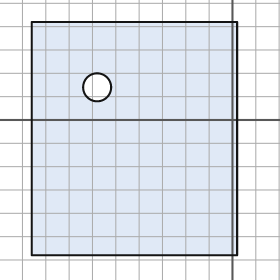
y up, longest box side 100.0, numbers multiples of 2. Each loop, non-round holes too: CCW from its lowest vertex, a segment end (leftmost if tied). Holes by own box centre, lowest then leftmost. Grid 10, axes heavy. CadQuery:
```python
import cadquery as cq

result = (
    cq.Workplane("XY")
    .moveTo(-86.0, -58.0)
    .lineTo(2.0, -58.0)
    .lineTo(2.0, 42.0)
    .lineTo(-86.0, 42.0)
    .close()
    .moveTo(-58.0, 14.0)
    .circle(6.0)
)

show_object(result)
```